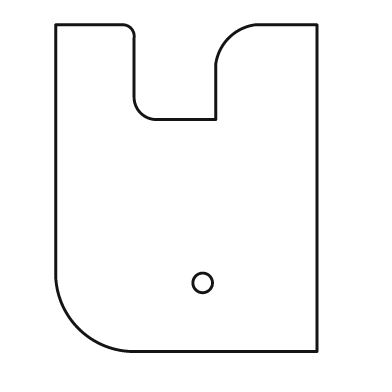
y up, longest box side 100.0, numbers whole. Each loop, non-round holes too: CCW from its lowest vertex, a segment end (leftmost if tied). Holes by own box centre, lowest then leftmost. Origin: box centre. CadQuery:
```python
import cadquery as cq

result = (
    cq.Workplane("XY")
    .moveTo(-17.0, -50.0)
    .lineTo(40.0, -50.0)
    .lineTo(40.0, 50.0)
    .lineTo(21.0, 50.0)
    .threePointArc((13.0, 46.0), (9.0, 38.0))
    .lineTo(9.0, 21.0)
    .lineTo(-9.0, 21.0)
    .threePointArc((-14.0, 23.0), (-16.0, 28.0))
    .lineTo(-16.0, 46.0)
    .threePointArc((-17.0, 49.0), (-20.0, 50.0))
    .lineTo(-40.0, 50.0)
    .lineTo(-40.0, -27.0)
    .threePointArc((-33.0, -43.0), (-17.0, -50.0))
    .close()
    .moveTo(5.0, -29.0)
    .circle(3.0)
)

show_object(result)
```